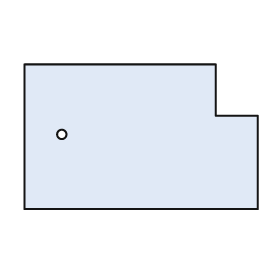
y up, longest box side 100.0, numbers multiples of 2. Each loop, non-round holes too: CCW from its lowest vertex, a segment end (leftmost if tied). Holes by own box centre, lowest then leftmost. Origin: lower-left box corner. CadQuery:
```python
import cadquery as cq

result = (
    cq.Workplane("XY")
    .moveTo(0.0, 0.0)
    .lineTo(100.0, 0.0)
    .lineTo(100.0, 40.0)
    .lineTo(82.0, 40.0)
    .lineTo(82.0, 62.0)
    .lineTo(0.0, 62.0)
    .close()
    .moveTo(16.0, 32.0)
    .circle(2.0)
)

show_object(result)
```